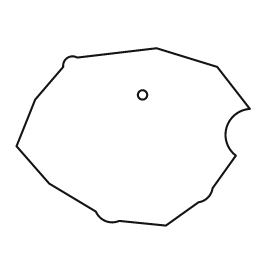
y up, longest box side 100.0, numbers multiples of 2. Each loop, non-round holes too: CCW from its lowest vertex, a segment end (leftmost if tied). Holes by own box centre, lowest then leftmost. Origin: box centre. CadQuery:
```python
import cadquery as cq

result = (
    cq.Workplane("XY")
    .moveTo(14.0, -38.0)
    .lineTo(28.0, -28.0)
    .threePointArc((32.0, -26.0), (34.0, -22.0))
    .lineTo(44.0, -8.0)
    .threePointArc((40.0, 4.0), (50.0, 12.0))
    .lineTo(36.0, 30.0)
    .lineTo(10.0, 38.0)
    .lineTo(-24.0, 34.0)
    .threePointArc((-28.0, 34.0), (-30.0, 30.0))
    .lineTo(-42.0, 16.0)
    .lineTo(-50.0, -4.0)
    .lineTo(-36.0, -20.0)
    .lineTo(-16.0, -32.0)
    .threePointArc((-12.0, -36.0), (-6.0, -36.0))
    .close()
    .moveTo(4.0, 18.0)
    .circle(2.0)
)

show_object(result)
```